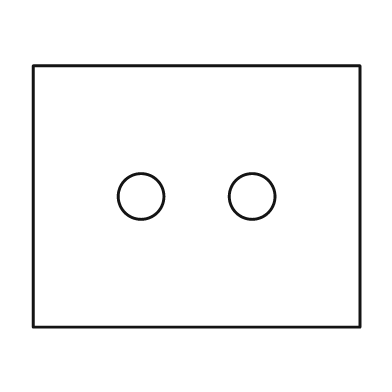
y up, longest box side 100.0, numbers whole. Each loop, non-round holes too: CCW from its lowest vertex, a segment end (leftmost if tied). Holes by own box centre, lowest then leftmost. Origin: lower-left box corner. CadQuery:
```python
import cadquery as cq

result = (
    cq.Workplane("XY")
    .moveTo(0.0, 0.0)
    .lineTo(100.0, 0.0)
    .lineTo(100.0, 80.0)
    .lineTo(0.0, 80.0)
    .close()
    .moveTo(33.0, 40.0)
    .circle(7.0)
    .moveTo(67.0, 40.0)
    .circle(7.0)
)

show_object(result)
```